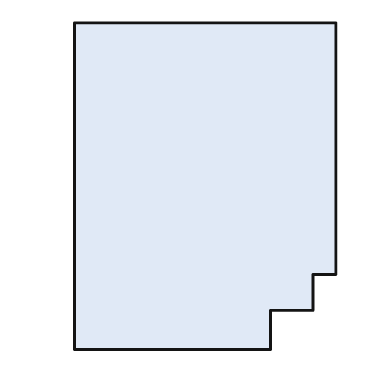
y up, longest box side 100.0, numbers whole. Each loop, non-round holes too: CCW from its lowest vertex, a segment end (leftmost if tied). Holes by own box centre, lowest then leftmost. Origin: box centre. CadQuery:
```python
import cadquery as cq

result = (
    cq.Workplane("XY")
    .moveTo(-40.0, -50.0)
    .lineTo(20.0, -50.0)
    .lineTo(20.0, -38.0)
    .lineTo(33.0, -38.0)
    .lineTo(33.0, -27.0)
    .lineTo(40.0, -27.0)
    .lineTo(40.0, 50.0)
    .lineTo(-40.0, 50.0)
    .close()
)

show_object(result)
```